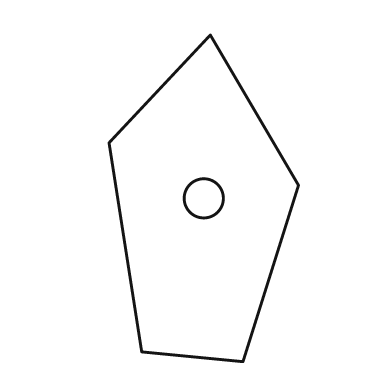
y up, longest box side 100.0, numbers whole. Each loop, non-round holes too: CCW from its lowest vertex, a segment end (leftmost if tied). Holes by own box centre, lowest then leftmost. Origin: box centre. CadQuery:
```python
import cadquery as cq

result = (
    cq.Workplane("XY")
    .moveTo(12.0, -50.0)
    .lineTo(29.0, 4.0)
    .lineTo(2.0, 50.0)
    .lineTo(-29.0, 17.0)
    .lineTo(-19.0, -47.0)
    .close()
    .moveTo(0.0, 0.0)
    .circle(6.0)
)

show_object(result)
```